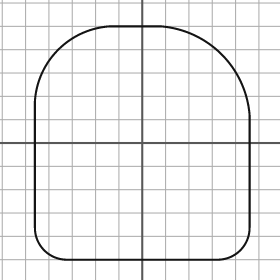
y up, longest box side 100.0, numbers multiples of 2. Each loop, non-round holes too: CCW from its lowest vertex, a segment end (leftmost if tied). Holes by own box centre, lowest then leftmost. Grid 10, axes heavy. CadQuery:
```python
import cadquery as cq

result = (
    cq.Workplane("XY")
    .moveTo(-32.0, -50.0)
    .lineTo(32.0, -50.0)
    .threePointArc((42.0, -46.0), (46.0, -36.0))
    .lineTo(46.0, 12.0)
    .threePointArc((34.0, 38.0), (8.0, 50.0))
    .lineTo(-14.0, 50.0)
    .threePointArc((-36.0, 40.0), (-46.0, 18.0))
    .lineTo(-46.0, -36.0)
    .threePointArc((-42.0, -46.0), (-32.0, -50.0))
    .close()
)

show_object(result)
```